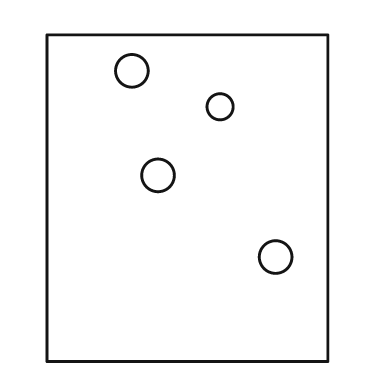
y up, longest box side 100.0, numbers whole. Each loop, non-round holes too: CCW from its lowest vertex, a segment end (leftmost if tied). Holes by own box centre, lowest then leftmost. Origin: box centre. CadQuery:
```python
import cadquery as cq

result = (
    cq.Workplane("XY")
    .moveTo(-43.0, -50.0)
    .lineTo(43.0, -50.0)
    .lineTo(43.0, 50.0)
    .lineTo(-43.0, 50.0)
    .close()
    .moveTo(27.0, -18.0)
    .circle(5.0)
    .moveTo(-9.0, 7.0)
    .circle(5.0)
    .moveTo(10.0, 28.0)
    .circle(4.0)
    .moveTo(-17.0, 39.0)
    .circle(5.0)
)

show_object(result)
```